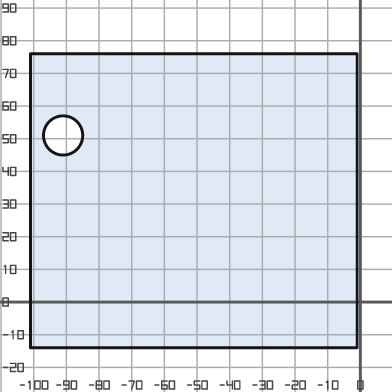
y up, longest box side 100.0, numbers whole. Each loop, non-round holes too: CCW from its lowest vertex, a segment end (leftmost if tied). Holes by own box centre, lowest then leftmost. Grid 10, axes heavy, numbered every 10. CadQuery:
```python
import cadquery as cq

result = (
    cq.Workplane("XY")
    .moveTo(-101.0, -14.0)
    .lineTo(-1.0, -14.0)
    .lineTo(-1.0, 76.0)
    .lineTo(-101.0, 76.0)
    .close()
    .moveTo(-91.0, 51.0)
    .circle(6.0)
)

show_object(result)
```